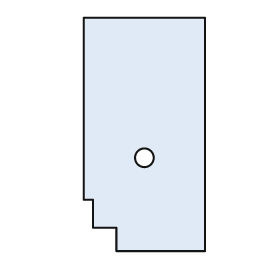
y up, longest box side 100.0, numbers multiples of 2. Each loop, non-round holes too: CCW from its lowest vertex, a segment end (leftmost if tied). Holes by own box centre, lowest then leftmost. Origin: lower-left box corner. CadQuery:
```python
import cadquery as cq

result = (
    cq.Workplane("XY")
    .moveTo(14.0, 0.0)
    .lineTo(52.0, 0.0)
    .lineTo(52.0, 100.0)
    .lineTo(0.0, 100.0)
    .lineTo(0.0, 22.0)
    .lineTo(4.0, 22.0)
    .lineTo(4.0, 10.0)
    .lineTo(14.0, 10.0)
    .close()
    .moveTo(26.0, 40.0)
    .circle(4.0)
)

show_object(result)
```